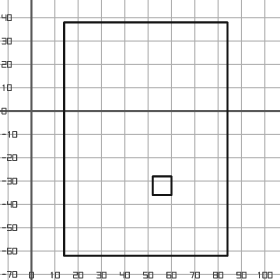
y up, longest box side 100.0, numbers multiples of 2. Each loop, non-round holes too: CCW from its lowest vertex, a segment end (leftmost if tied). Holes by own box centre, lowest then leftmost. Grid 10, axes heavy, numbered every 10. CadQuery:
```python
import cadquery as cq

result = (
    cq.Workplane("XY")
    .moveTo(14.0, -62.0)
    .lineTo(84.0, -62.0)
    .lineTo(84.0, 38.0)
    .lineTo(14.0, 38.0)
    .close()
    .moveTo(52.0, -36.0)
    .lineTo(60.0, -36.0)
    .lineTo(60.0, -28.0)
    .lineTo(52.0, -28.0)
    .close()
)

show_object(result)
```